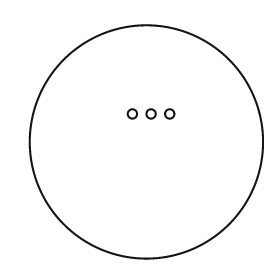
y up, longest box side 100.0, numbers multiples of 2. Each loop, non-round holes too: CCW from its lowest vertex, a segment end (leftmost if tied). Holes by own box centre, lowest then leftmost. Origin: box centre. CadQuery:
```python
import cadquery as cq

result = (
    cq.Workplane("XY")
    .moveTo(0.0, 0.0)
    .circle(50.0)
    .moveTo(-6.0, 12.0)
    .circle(2.0)
    .moveTo(2.0, 12.0)
    .circle(2.0)
    .moveTo(10.0, 12.0)
    .circle(2.0)
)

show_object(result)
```